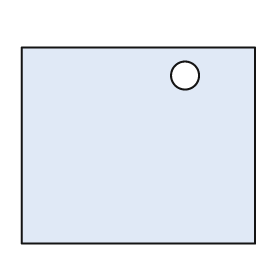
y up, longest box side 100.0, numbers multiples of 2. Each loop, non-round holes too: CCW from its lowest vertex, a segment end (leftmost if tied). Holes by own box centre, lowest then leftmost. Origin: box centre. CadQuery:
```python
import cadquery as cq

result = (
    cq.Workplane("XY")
    .moveTo(-50.0, -42.0)
    .lineTo(50.0, -42.0)
    .lineTo(50.0, 42.0)
    .lineTo(-50.0, 42.0)
    .close()
    .moveTo(20.0, 30.0)
    .circle(6.0)
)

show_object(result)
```